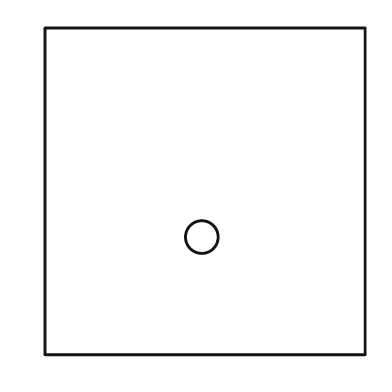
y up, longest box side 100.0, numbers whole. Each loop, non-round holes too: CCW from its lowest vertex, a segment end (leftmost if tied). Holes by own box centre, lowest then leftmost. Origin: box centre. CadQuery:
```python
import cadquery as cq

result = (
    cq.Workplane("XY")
    .moveTo(-49.0, -50.0)
    .lineTo(49.0, -50.0)
    .lineTo(49.0, 50.0)
    .lineTo(-49.0, 50.0)
    .close()
    .moveTo(-1.0, -14.0)
    .circle(5.0)
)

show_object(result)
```